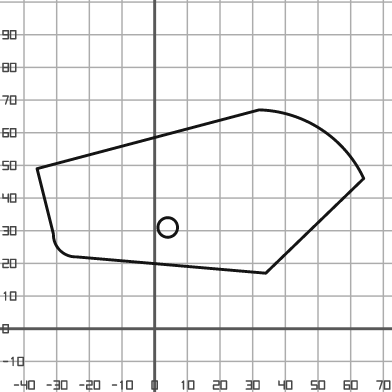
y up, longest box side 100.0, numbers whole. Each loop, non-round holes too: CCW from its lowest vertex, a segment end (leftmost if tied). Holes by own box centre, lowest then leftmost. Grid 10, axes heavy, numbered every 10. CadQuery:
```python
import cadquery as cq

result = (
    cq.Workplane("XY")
    .moveTo(34.0, 17.0)
    .lineTo(64.0, 46.0)
    .threePointArc((51.0, 61.0), (32.0, 67.0))
    .lineTo(-36.0, 49.0)
    .lineTo(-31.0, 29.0)
    .threePointArc((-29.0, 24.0), (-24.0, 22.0))
    .close()
    .moveTo(4.0, 31.0)
    .circle(3.0)
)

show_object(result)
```